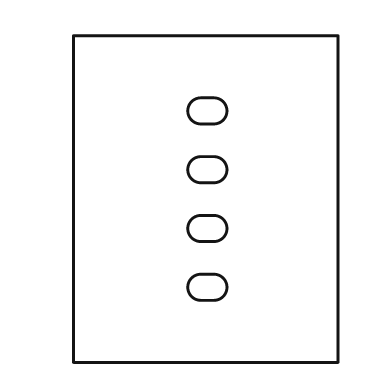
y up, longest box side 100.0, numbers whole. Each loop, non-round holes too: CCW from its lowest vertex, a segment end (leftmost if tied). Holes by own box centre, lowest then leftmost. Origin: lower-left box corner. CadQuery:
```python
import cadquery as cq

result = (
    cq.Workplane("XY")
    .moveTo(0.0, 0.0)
    .lineTo(81.0, 0.0)
    .lineTo(81.0, 100.0)
    .lineTo(0.0, 100.0)
    .close()
    .moveTo(39.0, 19.0)
    .lineTo(43.0, 19.0)
    .threePointArc((47.0, 23.0), (43.0, 27.0))
    .lineTo(39.0, 27.0)
    .threePointArc((35.0, 23.0), (39.0, 19.0))
    .close()
    .moveTo(39.0, 37.0)
    .lineTo(43.0, 37.0)
    .threePointArc((47.0, 41.0), (43.0, 45.0))
    .lineTo(39.0, 45.0)
    .threePointArc((35.0, 41.0), (39.0, 37.0))
    .close()
    .moveTo(39.0, 55.0)
    .lineTo(43.0, 55.0)
    .threePointArc((47.0, 59.0), (43.0, 63.0))
    .lineTo(39.0, 63.0)
    .threePointArc((35.0, 59.0), (39.0, 55.0))
    .close()
    .moveTo(39.0, 73.0)
    .lineTo(43.0, 73.0)
    .threePointArc((47.0, 77.0), (43.0, 81.0))
    .lineTo(39.0, 81.0)
    .threePointArc((35.0, 77.0), (39.0, 73.0))
    .close()
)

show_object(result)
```